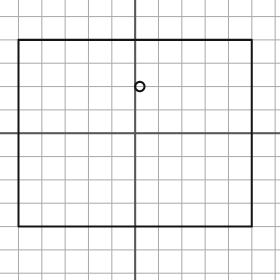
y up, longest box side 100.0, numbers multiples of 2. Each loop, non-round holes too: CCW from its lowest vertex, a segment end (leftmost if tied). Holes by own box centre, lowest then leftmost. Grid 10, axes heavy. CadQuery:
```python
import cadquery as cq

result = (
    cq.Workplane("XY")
    .moveTo(-50.0, -40.0)
    .lineTo(50.0, -40.0)
    .lineTo(50.0, 40.0)
    .lineTo(-50.0, 40.0)
    .close()
    .moveTo(2.0, 20.0)
    .circle(2.0)
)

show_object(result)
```